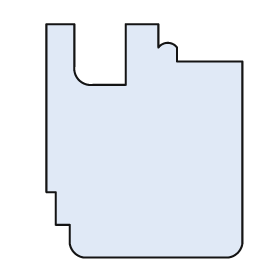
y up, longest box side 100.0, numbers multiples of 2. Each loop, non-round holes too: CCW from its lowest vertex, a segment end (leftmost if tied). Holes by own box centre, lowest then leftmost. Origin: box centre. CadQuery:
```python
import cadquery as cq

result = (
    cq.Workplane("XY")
    .moveTo(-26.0, -50.0)
    .lineTo(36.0, -50.0)
    .threePointArc((40.0, -48.0), (42.0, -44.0))
    .lineTo(42.0, 34.0)
    .lineTo(14.0, 34.0)
    .lineTo(14.0, 40.0)
    .threePointArc((10.0, 42.0), (6.0, 40.0))
    .lineTo(6.0, 50.0)
    .lineTo(-8.0, 50.0)
    .lineTo(-8.0, 24.0)
    .lineTo(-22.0, 24.0)
    .threePointArc((-28.0, 26.0), (-30.0, 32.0))
    .lineTo(-30.0, 50.0)
    .lineTo(-42.0, 50.0)
    .lineTo(-42.0, -22.0)
    .lineTo(-38.0, -22.0)
    .lineTo(-38.0, -36.0)
    .lineTo(-32.0, -36.0)
    .lineTo(-32.0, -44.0)
    .threePointArc((-30.0, -48.0), (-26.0, -50.0))
    .close()
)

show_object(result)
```